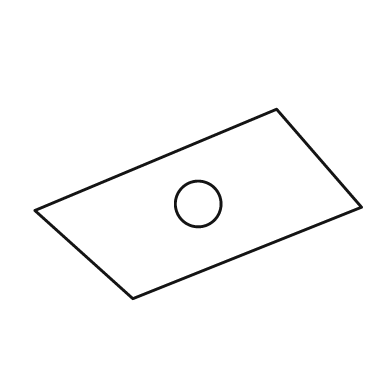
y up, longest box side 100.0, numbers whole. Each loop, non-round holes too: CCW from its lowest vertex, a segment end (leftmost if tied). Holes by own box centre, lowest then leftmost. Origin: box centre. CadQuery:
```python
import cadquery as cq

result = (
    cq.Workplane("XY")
    .moveTo(-20.0, -29.0)
    .lineTo(50.0, -1.0)
    .lineTo(24.0, 29.0)
    .lineTo(-50.0, -2.0)
    .close()
    .moveTo(0.0, 0.0)
    .circle(7.0)
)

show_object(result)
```